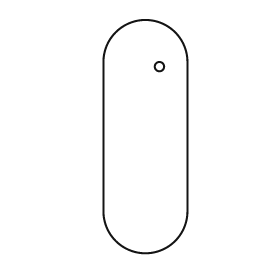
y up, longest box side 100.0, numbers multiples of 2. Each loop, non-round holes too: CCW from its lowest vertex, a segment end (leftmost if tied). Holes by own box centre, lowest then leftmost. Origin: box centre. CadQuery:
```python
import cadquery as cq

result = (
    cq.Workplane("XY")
    .moveTo(-18.0, -32.0)
    .threePointArc((0.0, -50.0), (18.0, -32.0))
    .lineTo(18.0, 32.0)
    .threePointArc((0.0, 50.0), (-18.0, 32.0))
    .close()
    .moveTo(6.0, 30.0)
    .circle(2.0)
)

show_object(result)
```